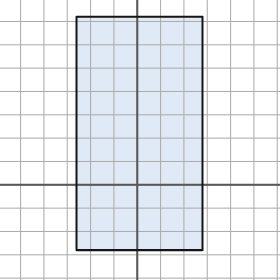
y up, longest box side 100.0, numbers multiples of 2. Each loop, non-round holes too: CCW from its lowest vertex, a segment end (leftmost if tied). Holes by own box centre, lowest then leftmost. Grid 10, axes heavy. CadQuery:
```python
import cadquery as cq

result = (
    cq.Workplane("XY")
    .moveTo(-26.0, -28.0)
    .lineTo(28.0, -28.0)
    .lineTo(28.0, 72.0)
    .lineTo(-26.0, 72.0)
    .close()
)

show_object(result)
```